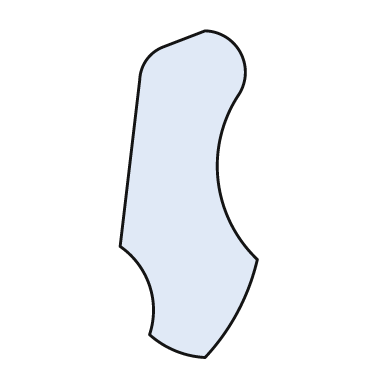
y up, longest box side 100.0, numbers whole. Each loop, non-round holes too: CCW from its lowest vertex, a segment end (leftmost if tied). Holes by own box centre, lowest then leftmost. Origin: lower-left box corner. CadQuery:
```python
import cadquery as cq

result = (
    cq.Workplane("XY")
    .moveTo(26.0, 0.0)
    .threePointArc((36.0, 14.0), (42.0, 30.0))
    .threePointArc((30.0, 54.0), (36.0, 80.0))
    .threePointArc((37.0, 93.0), (26.0, 100.0))
    .lineTo(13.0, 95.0)
    .threePointArc((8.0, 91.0), (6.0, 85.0))
    .lineTo(0.0, 34.0)
    .threePointArc((9.0, 22.0), (9.0, 7.0))
    .threePointArc((17.0, 2.0), (26.0, 0.0))
    .close()
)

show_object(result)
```